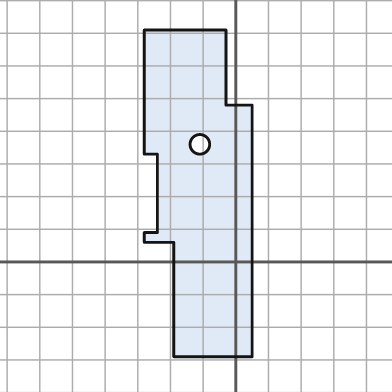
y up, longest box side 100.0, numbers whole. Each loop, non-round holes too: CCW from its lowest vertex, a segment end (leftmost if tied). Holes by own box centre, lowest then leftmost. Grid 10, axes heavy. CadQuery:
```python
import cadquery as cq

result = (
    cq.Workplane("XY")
    .moveTo(-19.0, -29.0)
    .lineTo(5.0, -29.0)
    .lineTo(5.0, 48.0)
    .lineTo(-3.0, 48.0)
    .lineTo(-3.0, 71.0)
    .lineTo(-28.0, 71.0)
    .lineTo(-28.0, 33.0)
    .lineTo(-24.0, 33.0)
    .lineTo(-24.0, 9.0)
    .lineTo(-28.0, 9.0)
    .lineTo(-28.0, 6.0)
    .lineTo(-19.0, 6.0)
    .close()
    .moveTo(-11.0, 36.0)
    .circle(3.0)
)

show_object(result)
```